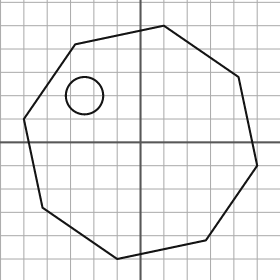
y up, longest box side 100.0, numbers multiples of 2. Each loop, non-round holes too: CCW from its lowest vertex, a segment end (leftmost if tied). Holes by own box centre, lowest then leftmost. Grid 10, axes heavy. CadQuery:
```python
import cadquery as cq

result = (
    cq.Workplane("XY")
    .moveTo(-10.0, -50.0)
    .lineTo(28.0, -42.0)
    .lineTo(50.0, -10.0)
    .lineTo(42.0, 28.0)
    .lineTo(10.0, 50.0)
    .lineTo(-28.0, 42.0)
    .lineTo(-50.0, 10.0)
    .lineTo(-42.0, -28.0)
    .close()
    .moveTo(-24.0, 20.0)
    .circle(8.0)
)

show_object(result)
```